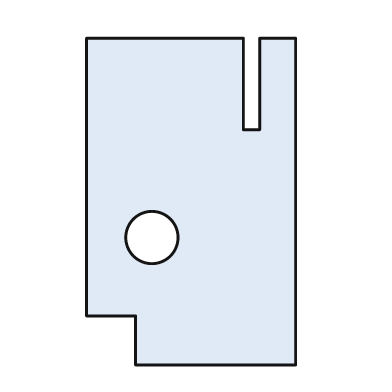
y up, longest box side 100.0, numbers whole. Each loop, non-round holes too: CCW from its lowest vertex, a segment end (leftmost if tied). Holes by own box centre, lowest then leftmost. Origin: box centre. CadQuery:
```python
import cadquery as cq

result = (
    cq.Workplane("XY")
    .moveTo(-17.0, -50.0)
    .lineTo(32.0, -50.0)
    .lineTo(32.0, 50.0)
    .lineTo(21.0, 50.0)
    .lineTo(21.0, 22.0)
    .lineTo(16.0, 22.0)
    .lineTo(16.0, 50.0)
    .lineTo(-32.0, 50.0)
    .lineTo(-32.0, -35.0)
    .lineTo(-17.0, -35.0)
    .close()
    .moveTo(-12.0, -11.0)
    .circle(8.0)
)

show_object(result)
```